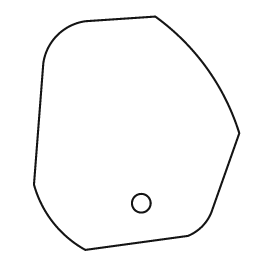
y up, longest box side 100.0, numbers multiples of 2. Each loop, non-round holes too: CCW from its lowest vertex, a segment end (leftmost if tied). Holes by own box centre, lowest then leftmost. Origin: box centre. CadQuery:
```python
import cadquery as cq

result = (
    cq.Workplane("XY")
    .moveTo(-22.0, -50.0)
    .lineTo(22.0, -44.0)
    .threePointArc((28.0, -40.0), (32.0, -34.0))
    .lineTo(44.0, 0.0)
    .threePointArc((30.0, 28.0), (8.0, 50.0))
    .lineTo(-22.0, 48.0)
    .threePointArc((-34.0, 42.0), (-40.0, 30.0))
    .lineTo(-44.0, -22.0)
    .threePointArc((-36.0, -38.0), (-22.0, -50.0))
    .close()
    .moveTo(2.0, -30.0)
    .circle(4.0)
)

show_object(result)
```